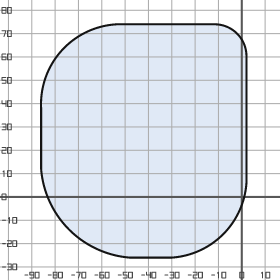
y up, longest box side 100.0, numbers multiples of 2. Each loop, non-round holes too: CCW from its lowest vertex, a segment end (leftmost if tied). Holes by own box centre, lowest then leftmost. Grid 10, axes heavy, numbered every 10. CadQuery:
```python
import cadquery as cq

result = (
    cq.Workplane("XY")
    .moveTo(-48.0, -26.0)
    .lineTo(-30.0, -26.0)
    .threePointArc((-8.0, -16.0), (2.0, 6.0))
    .lineTo(2.0, 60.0)
    .threePointArc((-2.0, 70.0), (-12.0, 74.0))
    .lineTo(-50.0, 74.0)
    .threePointArc((-76.0, 64.0), (-86.0, 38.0))
    .lineTo(-86.0, 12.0)
    .threePointArc((-74.0, -14.0), (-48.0, -26.0))
    .close()
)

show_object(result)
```